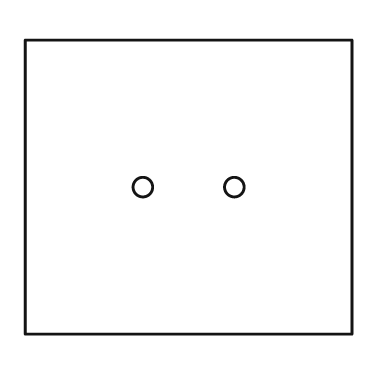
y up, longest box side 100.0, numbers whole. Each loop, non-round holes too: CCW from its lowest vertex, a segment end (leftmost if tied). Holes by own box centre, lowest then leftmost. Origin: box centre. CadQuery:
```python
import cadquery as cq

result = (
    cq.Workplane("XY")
    .moveTo(-50.0, -45.0)
    .lineTo(50.0, -45.0)
    .lineTo(50.0, 45.0)
    .lineTo(-50.0, 45.0)
    .close()
    .moveTo(-14.0, 0.0)
    .circle(3.0)
    .moveTo(14.0, 0.0)
    .circle(3.0)
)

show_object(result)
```